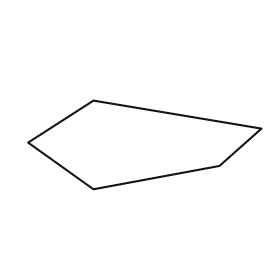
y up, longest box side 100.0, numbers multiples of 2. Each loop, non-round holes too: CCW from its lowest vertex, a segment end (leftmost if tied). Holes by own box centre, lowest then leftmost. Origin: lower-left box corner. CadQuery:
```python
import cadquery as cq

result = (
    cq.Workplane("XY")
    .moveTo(28.0, 0.0)
    .lineTo(82.0, 10.0)
    .lineTo(100.0, 26.0)
    .lineTo(28.0, 38.0)
    .lineTo(0.0, 20.0)
    .close()
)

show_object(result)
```